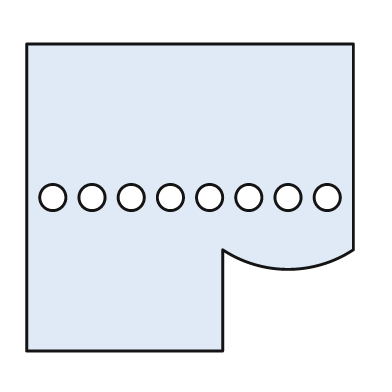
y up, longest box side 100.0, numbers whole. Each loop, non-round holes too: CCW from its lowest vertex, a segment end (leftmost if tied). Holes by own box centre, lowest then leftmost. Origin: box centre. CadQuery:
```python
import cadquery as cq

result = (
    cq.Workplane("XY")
    .moveTo(-50.0, -47.0)
    .lineTo(10.0, -47.0)
    .lineTo(10.0, -16.0)
    .threePointArc((30.0, -22.0), (50.0, -16.0))
    .lineTo(50.0, 47.0)
    .lineTo(-50.0, 47.0)
    .close()
    .moveTo(-42.0, 0.0)
    .circle(4.0)
    .moveTo(-30.0, 0.0)
    .circle(4.0)
    .moveTo(-18.0, 0.0)
    .circle(4.0)
    .moveTo(-6.0, 0.0)
    .circle(4.0)
    .moveTo(6.0, 0.0)
    .circle(4.0)
    .moveTo(18.0, 0.0)
    .circle(4.0)
    .moveTo(30.0, 0.0)
    .circle(4.0)
    .moveTo(42.0, 0.0)
    .circle(4.0)
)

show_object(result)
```